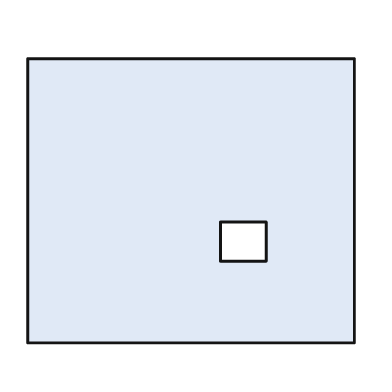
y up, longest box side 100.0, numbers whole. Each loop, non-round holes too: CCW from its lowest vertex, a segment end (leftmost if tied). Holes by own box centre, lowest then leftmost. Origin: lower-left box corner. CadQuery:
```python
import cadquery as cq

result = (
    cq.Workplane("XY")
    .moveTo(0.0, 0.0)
    .lineTo(100.0, 0.0)
    .lineTo(100.0, 87.0)
    .lineTo(0.0, 87.0)
    .close()
    .moveTo(59.0, 25.0)
    .lineTo(73.0, 25.0)
    .lineTo(73.0, 37.0)
    .lineTo(59.0, 37.0)
    .close()
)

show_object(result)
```